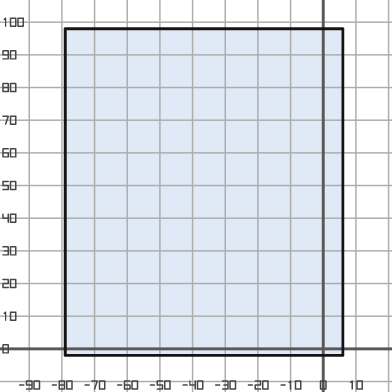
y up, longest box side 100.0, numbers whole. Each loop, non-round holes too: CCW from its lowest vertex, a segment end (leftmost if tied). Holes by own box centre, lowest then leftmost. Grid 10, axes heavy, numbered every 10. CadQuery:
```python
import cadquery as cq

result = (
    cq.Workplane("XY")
    .moveTo(-79.0, -2.0)
    .lineTo(6.0, -2.0)
    .lineTo(6.0, 98.0)
    .lineTo(-79.0, 98.0)
    .close()
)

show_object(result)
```